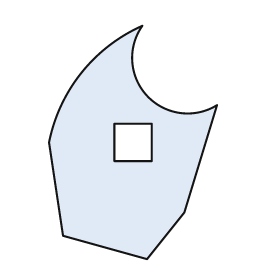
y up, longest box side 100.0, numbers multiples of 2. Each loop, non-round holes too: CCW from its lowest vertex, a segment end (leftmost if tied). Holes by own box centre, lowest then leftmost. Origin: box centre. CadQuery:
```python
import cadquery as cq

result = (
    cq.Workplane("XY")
    .moveTo(6.0, -50.0)
    .lineTo(22.0, -30.0)
    .lineTo(36.0, 16.0)
    .threePointArc((6.0, 20.0), (4.0, 50.0))
    .threePointArc((-22.0, 30.0), (-36.0, 0.0))
    .lineTo(-30.0, -40.0)
    .close()
    .moveTo(-8.0, -8.0)
    .lineTo(8.0, -8.0)
    .lineTo(8.0, 8.0)
    .lineTo(-8.0, 8.0)
    .close()
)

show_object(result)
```